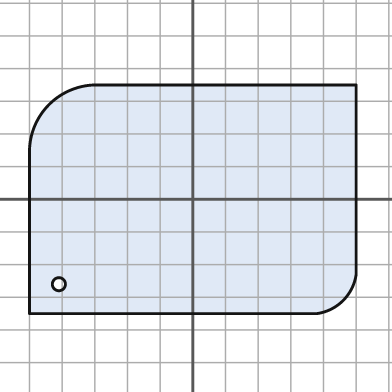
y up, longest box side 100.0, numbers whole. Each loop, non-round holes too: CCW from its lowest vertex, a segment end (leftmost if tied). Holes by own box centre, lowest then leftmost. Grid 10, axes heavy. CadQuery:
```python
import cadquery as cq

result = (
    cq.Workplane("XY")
    .moveTo(-50.0, -35.0)
    .lineTo(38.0, -35.0)
    .threePointArc((46.0, -31.0), (50.0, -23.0))
    .lineTo(50.0, 35.0)
    .lineTo(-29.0, 35.0)
    .threePointArc((-44.0, 29.0), (-50.0, 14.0))
    .close()
    .moveTo(-41.0, -26.0)
    .circle(2.0)
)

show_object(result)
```